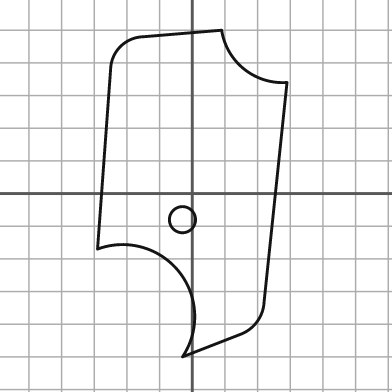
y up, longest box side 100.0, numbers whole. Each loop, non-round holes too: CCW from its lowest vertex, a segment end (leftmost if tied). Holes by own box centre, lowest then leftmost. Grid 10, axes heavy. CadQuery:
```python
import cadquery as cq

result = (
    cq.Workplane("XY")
    .moveTo(-3.0, -50.0)
    .lineTo(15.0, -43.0)
    .threePointArc((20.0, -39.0), (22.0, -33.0))
    .lineTo(29.0, 34.0)
    .threePointArc((16.0, 38.0), (9.0, 50.0))
    .lineTo(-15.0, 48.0)
    .threePointArc((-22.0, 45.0), (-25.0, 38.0))
    .lineTo(-29.0, -17.0)
    .threePointArc((-4.0, -24.0), (-3.0, -50.0))
    .close()
    .moveTo(-3.0, -8.0)
    .circle(4.0)
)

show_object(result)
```